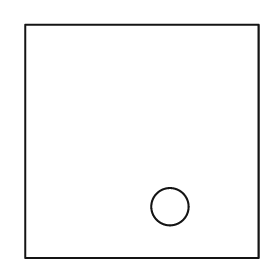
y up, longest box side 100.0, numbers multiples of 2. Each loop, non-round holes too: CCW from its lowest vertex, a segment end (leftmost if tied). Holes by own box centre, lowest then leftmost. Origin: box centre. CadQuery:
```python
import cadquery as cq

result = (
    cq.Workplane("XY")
    .moveTo(-50.0, -50.0)
    .lineTo(50.0, -50.0)
    .lineTo(50.0, 50.0)
    .lineTo(-50.0, 50.0)
    .close()
    .moveTo(12.0, -28.0)
    .circle(8.0)
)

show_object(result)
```